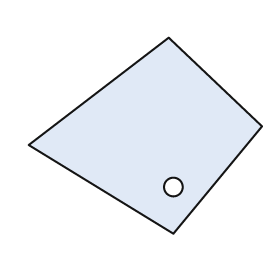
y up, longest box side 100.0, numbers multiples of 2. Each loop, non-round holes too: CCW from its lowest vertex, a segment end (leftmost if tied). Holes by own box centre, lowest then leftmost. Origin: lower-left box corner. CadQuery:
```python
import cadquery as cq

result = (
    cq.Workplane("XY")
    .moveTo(62.0, 0.0)
    .lineTo(100.0, 46.0)
    .lineTo(60.0, 84.0)
    .lineTo(0.0, 38.0)
    .close()
    .moveTo(62.0, 20.0)
    .circle(4.0)
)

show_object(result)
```